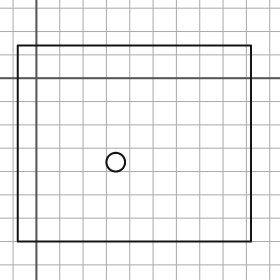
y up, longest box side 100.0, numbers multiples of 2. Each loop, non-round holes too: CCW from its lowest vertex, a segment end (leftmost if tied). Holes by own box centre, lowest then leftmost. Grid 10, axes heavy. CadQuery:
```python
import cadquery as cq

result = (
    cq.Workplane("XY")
    .moveTo(-8.0, -70.0)
    .lineTo(92.0, -70.0)
    .lineTo(92.0, 14.0)
    .lineTo(-8.0, 14.0)
    .close()
    .moveTo(34.0, -36.0)
    .circle(4.0)
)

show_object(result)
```